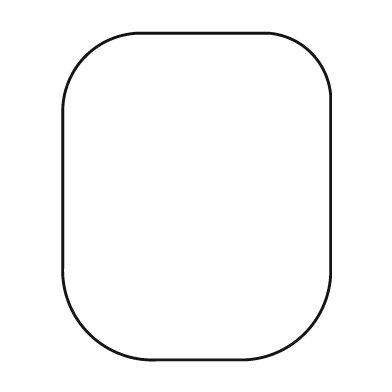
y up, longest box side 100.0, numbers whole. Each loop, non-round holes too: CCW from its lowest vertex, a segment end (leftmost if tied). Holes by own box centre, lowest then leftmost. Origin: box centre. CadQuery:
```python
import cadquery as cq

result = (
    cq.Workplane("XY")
    .moveTo(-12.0, -50.0)
    .lineTo(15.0, -50.0)
    .threePointArc((33.0, -42.0), (41.0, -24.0))
    .lineTo(41.0, 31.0)
    .threePointArc((35.0, 44.0), (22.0, 50.0))
    .lineTo(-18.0, 50.0)
    .threePointArc((-34.0, 43.0), (-41.0, 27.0))
    .lineTo(-41.0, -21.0)
    .threePointArc((-33.0, -42.0), (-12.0, -50.0))
    .close()
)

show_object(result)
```